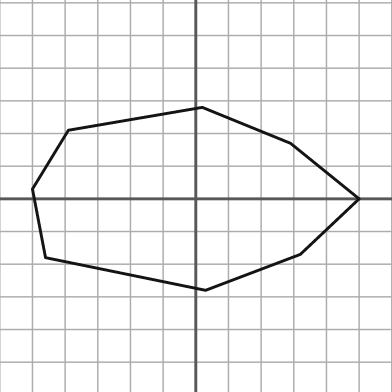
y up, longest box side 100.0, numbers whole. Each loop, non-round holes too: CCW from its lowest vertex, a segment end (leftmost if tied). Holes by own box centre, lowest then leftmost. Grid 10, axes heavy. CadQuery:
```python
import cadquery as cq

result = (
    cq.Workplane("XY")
    .moveTo(3.0, -28.0)
    .lineTo(32.0, -17.0)
    .lineTo(50.0, 0.0)
    .lineTo(29.0, 17.0)
    .lineTo(2.0, 28.0)
    .lineTo(-39.0, 21.0)
    .lineTo(-50.0, 3.0)
    .lineTo(-46.0, -18.0)
    .close()
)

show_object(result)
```